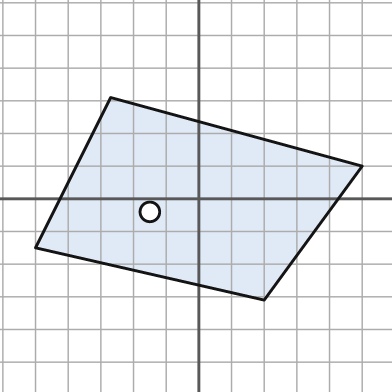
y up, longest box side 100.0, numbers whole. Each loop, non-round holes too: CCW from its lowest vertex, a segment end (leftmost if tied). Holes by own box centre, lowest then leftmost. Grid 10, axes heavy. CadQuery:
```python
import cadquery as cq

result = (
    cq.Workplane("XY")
    .moveTo(20.0, -31.0)
    .lineTo(50.0, 10.0)
    .lineTo(-27.0, 31.0)
    .lineTo(-50.0, -15.0)
    .close()
    .moveTo(-15.0, -4.0)
    .circle(3.0)
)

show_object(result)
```